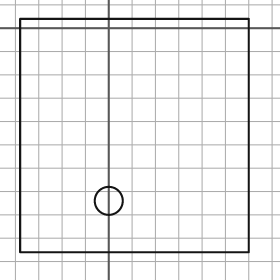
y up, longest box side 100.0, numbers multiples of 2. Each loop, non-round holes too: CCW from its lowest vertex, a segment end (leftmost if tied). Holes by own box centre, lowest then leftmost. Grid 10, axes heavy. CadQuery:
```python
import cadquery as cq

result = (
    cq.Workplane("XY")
    .moveTo(-38.0, -96.0)
    .lineTo(60.0, -96.0)
    .lineTo(60.0, 4.0)
    .lineTo(-38.0, 4.0)
    .close()
    .moveTo(0.0, -74.0)
    .circle(6.0)
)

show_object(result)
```